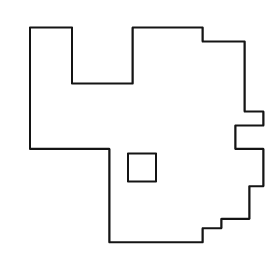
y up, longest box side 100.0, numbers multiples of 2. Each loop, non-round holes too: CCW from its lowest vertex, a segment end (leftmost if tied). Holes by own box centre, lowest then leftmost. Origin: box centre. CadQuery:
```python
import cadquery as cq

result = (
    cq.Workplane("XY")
    .moveTo(-16.0, -46.0)
    .lineTo(24.0, -46.0)
    .lineTo(24.0, -40.0)
    .lineTo(32.0, -40.0)
    .lineTo(32.0, -36.0)
    .lineTo(44.0, -36.0)
    .lineTo(44.0, -22.0)
    .lineTo(50.0, -22.0)
    .lineTo(50.0, -6.0)
    .lineTo(38.0, -6.0)
    .lineTo(38.0, 4.0)
    .lineTo(50.0, 4.0)
    .lineTo(50.0, 10.0)
    .lineTo(42.0, 10.0)
    .lineTo(42.0, 40.0)
    .lineTo(24.0, 40.0)
    .lineTo(24.0, 46.0)
    .lineTo(-6.0, 46.0)
    .lineTo(-6.0, 22.0)
    .lineTo(-32.0, 22.0)
    .lineTo(-32.0, 46.0)
    .lineTo(-50.0, 46.0)
    .lineTo(-50.0, -6.0)
    .lineTo(-16.0, -6.0)
    .close()
    .moveTo(-8.0, -20.0)
    .lineTo(4.0, -20.0)
    .lineTo(4.0, -8.0)
    .lineTo(-8.0, -8.0)
    .close()
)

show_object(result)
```